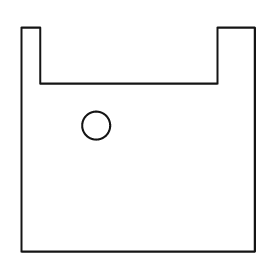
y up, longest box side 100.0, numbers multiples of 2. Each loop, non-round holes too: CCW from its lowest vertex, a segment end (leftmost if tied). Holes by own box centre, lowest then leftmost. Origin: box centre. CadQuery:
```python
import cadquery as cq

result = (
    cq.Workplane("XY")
    .moveTo(-50.0, -48.0)
    .lineTo(50.0, -48.0)
    .lineTo(50.0, 48.0)
    .lineTo(34.0, 48.0)
    .lineTo(34.0, 24.0)
    .lineTo(-42.0, 24.0)
    .lineTo(-42.0, 48.0)
    .lineTo(-50.0, 48.0)
    .close()
    .moveTo(-18.0, 6.0)
    .circle(6.0)
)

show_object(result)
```